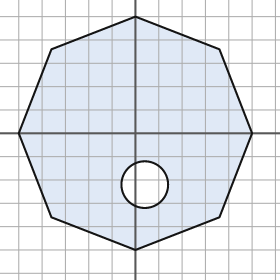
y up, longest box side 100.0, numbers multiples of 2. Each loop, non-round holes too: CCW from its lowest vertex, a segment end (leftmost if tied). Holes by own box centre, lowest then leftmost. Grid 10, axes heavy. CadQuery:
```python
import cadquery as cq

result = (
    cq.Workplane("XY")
    .moveTo(0.0, -50.0)
    .lineTo(36.0, -36.0)
    .lineTo(50.0, 0.0)
    .lineTo(36.0, 36.0)
    .lineTo(0.0, 50.0)
    .lineTo(-36.0, 36.0)
    .lineTo(-50.0, 0.0)
    .lineTo(-36.0, -36.0)
    .close()
    .moveTo(4.0, -22.0)
    .circle(10.0)
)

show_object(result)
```